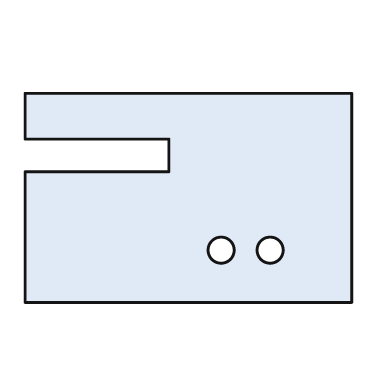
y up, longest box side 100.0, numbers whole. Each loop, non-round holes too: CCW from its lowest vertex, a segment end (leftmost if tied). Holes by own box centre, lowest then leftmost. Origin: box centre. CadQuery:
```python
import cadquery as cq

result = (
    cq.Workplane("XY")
    .moveTo(-50.0, -32.0)
    .lineTo(50.0, -32.0)
    .lineTo(50.0, 32.0)
    .lineTo(-50.0, 32.0)
    .lineTo(-50.0, 18.0)
    .lineTo(-6.0, 18.0)
    .lineTo(-6.0, 8.0)
    .lineTo(-50.0, 8.0)
    .close()
    .moveTo(10.0, -16.0)
    .circle(4.0)
    .moveTo(25.0, -16.0)
    .circle(4.0)
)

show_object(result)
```